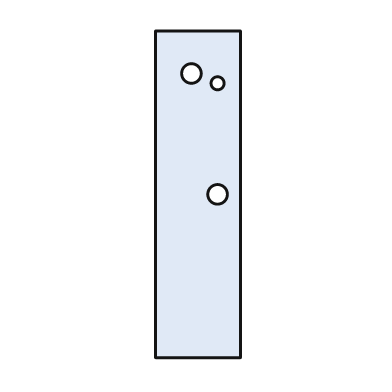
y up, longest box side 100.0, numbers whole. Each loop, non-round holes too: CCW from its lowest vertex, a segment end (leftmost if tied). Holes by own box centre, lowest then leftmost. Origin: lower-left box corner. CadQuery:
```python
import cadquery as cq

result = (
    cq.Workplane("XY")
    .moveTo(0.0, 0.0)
    .lineTo(26.0, 0.0)
    .lineTo(26.0, 100.0)
    .lineTo(0.0, 100.0)
    .close()
    .moveTo(19.0, 50.0)
    .circle(3.0)
    .moveTo(19.0, 84.0)
    .circle(2.0)
    .moveTo(11.0, 87.0)
    .circle(3.0)
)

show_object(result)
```